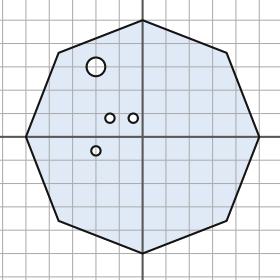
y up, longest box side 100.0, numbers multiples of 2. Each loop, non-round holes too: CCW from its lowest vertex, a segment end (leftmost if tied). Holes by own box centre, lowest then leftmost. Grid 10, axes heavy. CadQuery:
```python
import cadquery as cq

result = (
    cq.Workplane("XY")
    .moveTo(0.0, -50.0)
    .lineTo(36.0, -36.0)
    .lineTo(50.0, 0.0)
    .lineTo(36.0, 36.0)
    .lineTo(0.0, 50.0)
    .lineTo(-36.0, 36.0)
    .lineTo(-50.0, 0.0)
    .lineTo(-36.0, -36.0)
    .close()
    .moveTo(-20.0, -6.0)
    .circle(2.0)
    .moveTo(-14.0, 8.0)
    .circle(2.0)
    .moveTo(-4.0, 8.0)
    .circle(2.0)
    .moveTo(-20.0, 30.0)
    .circle(4.0)
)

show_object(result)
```